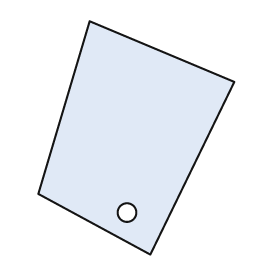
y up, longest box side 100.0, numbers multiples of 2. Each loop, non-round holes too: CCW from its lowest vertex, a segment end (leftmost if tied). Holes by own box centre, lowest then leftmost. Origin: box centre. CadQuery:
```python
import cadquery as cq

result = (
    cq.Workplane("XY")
    .moveTo(6.0, -50.0)
    .lineTo(42.0, 24.0)
    .lineTo(-20.0, 50.0)
    .lineTo(-42.0, -24.0)
    .close()
    .moveTo(-4.0, -32.0)
    .circle(4.0)
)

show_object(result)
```